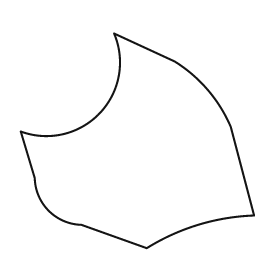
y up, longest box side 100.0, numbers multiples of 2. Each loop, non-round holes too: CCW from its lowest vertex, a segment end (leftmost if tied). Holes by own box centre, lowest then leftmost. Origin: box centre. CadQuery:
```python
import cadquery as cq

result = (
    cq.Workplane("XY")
    .moveTo(4.0, -46.0)
    .threePointArc((26.0, -36.0), (50.0, -32.0))
    .lineTo(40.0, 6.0)
    .threePointArc((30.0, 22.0), (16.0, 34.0))
    .lineTo(-10.0, 46.0)
    .threePointArc((-16.0, 12.0), (-50.0, 4.0))
    .lineTo(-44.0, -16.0)
    .threePointArc((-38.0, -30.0), (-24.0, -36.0))
    .close()
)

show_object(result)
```